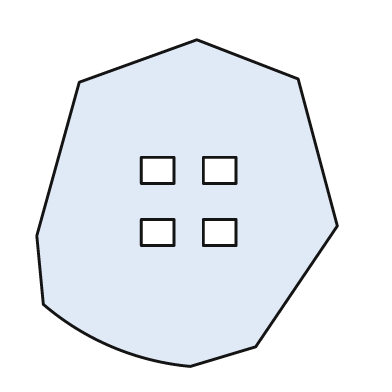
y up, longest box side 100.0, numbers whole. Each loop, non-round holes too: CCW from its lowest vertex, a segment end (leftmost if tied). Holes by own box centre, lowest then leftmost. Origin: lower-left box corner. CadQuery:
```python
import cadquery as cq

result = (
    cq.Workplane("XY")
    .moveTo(47.0, 0.0)
    .lineTo(67.0, 6.0)
    .lineTo(92.0, 43.0)
    .lineTo(80.0, 88.0)
    .lineTo(49.0, 100.0)
    .lineTo(13.0, 87.0)
    .lineTo(0.0, 40.0)
    .lineTo(2.0, 19.0)
    .threePointArc((23.0, 6.0), (47.0, 0.0))
    .close()
    .moveTo(32.0, 37.0)
    .lineTo(42.0, 37.0)
    .lineTo(42.0, 45.0)
    .lineTo(32.0, 45.0)
    .close()
    .moveTo(51.0, 37.0)
    .lineTo(61.0, 37.0)
    .lineTo(61.0, 45.0)
    .lineTo(51.0, 45.0)
    .close()
    .moveTo(32.0, 56.0)
    .lineTo(42.0, 56.0)
    .lineTo(42.0, 64.0)
    .lineTo(32.0, 64.0)
    .close()
    .moveTo(51.0, 56.0)
    .lineTo(61.0, 56.0)
    .lineTo(61.0, 64.0)
    .lineTo(51.0, 64.0)
    .close()
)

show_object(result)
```